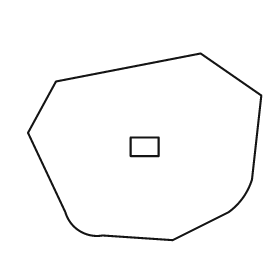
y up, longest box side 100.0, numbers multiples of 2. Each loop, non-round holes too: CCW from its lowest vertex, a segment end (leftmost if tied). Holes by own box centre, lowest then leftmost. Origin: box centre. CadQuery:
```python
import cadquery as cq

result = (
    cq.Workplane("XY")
    .moveTo(12.0, -40.0)
    .lineTo(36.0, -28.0)
    .threePointArc((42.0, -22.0), (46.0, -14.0))
    .lineTo(50.0, 22.0)
    .lineTo(24.0, 40.0)
    .lineTo(-38.0, 28.0)
    .lineTo(-50.0, 6.0)
    .lineTo(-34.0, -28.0)
    .threePointArc((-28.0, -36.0), (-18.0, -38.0))
    .close()
    .moveTo(-6.0, -4.0)
    .lineTo(6.0, -4.0)
    .lineTo(6.0, 4.0)
    .lineTo(-6.0, 4.0)
    .close()
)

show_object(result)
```